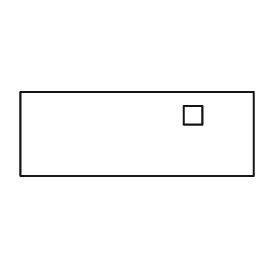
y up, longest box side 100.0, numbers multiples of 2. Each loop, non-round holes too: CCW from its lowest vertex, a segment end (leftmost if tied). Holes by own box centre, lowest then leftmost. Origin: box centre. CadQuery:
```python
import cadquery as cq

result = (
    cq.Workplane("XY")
    .moveTo(-50.0, -18.0)
    .lineTo(50.0, -18.0)
    .lineTo(50.0, 18.0)
    .lineTo(-50.0, 18.0)
    .close()
    .moveTo(20.0, 4.0)
    .lineTo(28.0, 4.0)
    .lineTo(28.0, 12.0)
    .lineTo(20.0, 12.0)
    .close()
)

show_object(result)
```